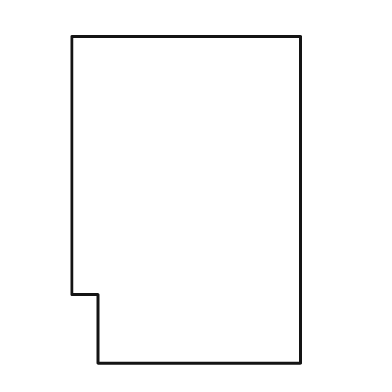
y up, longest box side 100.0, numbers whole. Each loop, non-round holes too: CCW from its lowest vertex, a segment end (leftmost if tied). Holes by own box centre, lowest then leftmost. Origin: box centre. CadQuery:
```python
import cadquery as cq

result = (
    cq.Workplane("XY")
    .moveTo(-27.0, -50.0)
    .lineTo(35.0, -50.0)
    .lineTo(35.0, 50.0)
    .lineTo(-35.0, 50.0)
    .lineTo(-35.0, -29.0)
    .lineTo(-27.0, -29.0)
    .close()
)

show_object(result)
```